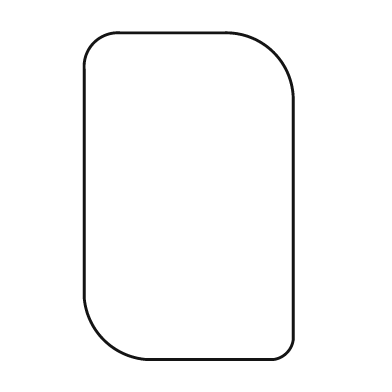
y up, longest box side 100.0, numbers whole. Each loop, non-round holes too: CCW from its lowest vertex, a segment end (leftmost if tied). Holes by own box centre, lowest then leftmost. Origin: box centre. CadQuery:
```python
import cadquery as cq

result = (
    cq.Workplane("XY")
    .moveTo(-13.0, -50.0)
    .lineTo(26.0, -50.0)
    .threePointArc((30.0, -48.0), (32.0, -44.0))
    .lineTo(32.0, 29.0)
    .threePointArc((26.0, 44.0), (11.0, 50.0))
    .lineTo(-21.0, 50.0)
    .threePointArc((-29.0, 47.0), (-32.0, 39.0))
    .lineTo(-32.0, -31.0)
    .threePointArc((-26.0, -44.0), (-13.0, -50.0))
    .close()
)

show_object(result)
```